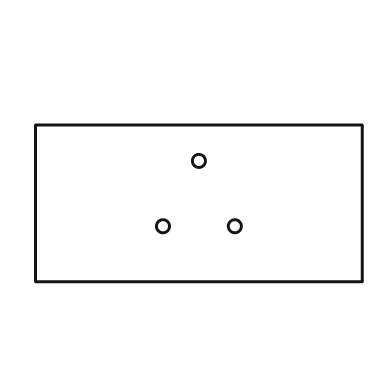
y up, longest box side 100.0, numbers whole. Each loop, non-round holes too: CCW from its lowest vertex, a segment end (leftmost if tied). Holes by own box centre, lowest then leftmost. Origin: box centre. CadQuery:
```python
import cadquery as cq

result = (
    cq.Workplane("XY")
    .moveTo(-50.0, -24.0)
    .lineTo(50.0, -24.0)
    .lineTo(50.0, 24.0)
    .lineTo(-50.0, 24.0)
    .close()
    .moveTo(-11.0, -7.0)
    .circle(2.0)
    .moveTo(11.0, -7.0)
    .circle(2.0)
    .moveTo(0.0, 13.0)
    .circle(2.0)
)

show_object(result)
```